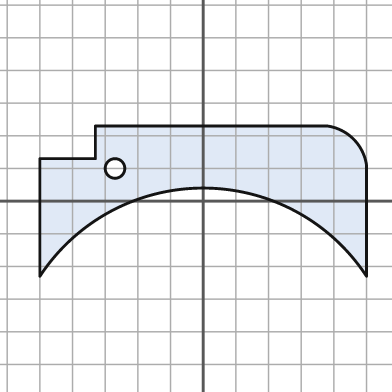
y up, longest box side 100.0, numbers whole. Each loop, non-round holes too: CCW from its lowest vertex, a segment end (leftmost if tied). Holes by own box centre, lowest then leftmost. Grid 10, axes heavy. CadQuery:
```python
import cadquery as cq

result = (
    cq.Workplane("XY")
    .moveTo(-50.0, -23.0)
    .threePointArc((0.0, 4.0), (50.0, -23.0))
    .lineTo(50.0, 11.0)
    .threePointArc((46.0, 19.0), (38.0, 23.0))
    .lineTo(-33.0, 23.0)
    .lineTo(-33.0, 13.0)
    .lineTo(-50.0, 13.0)
    .close()
    .moveTo(-27.0, 10.0)
    .circle(3.0)
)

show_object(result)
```